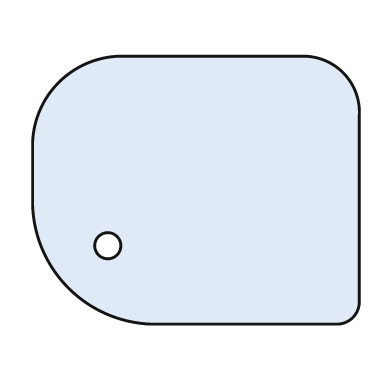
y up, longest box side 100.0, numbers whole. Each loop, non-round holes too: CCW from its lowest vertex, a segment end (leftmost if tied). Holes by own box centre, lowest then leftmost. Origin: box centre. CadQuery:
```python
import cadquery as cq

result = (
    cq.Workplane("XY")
    .moveTo(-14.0, -41.0)
    .lineTo(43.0, -41.0)
    .threePointArc((48.0, -39.0), (50.0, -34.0))
    .lineTo(50.0, 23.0)
    .threePointArc((45.0, 36.0), (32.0, 41.0))
    .lineTo(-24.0, 41.0)
    .threePointArc((-42.0, 33.0), (-50.0, 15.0))
    .lineTo(-50.0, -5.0)
    .threePointArc((-39.0, -30.0), (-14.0, -41.0))
    .close()
    .moveTo(-27.0, -17.0)
    .circle(4.0)
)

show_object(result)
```